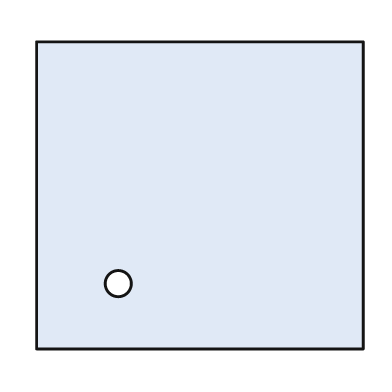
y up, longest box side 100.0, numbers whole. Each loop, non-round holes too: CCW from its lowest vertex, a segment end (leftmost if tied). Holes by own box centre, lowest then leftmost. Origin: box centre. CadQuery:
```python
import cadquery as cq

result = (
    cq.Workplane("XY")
    .moveTo(-50.0, -47.0)
    .lineTo(50.0, -47.0)
    .lineTo(50.0, 47.0)
    .lineTo(-50.0, 47.0)
    .close()
    .moveTo(-25.0, -27.0)
    .circle(4.0)
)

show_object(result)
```